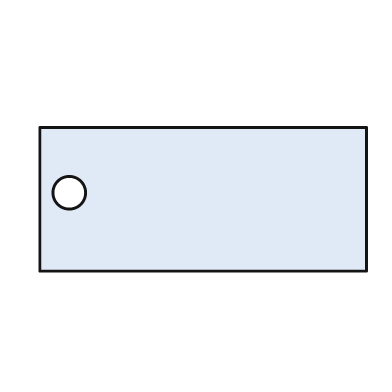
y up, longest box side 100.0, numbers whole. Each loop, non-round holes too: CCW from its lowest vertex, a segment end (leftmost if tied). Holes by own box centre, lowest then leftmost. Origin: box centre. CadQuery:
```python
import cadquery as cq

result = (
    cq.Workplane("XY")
    .moveTo(-50.0, -22.0)
    .lineTo(50.0, -22.0)
    .lineTo(50.0, 22.0)
    .lineTo(-50.0, 22.0)
    .close()
    .moveTo(-41.0, 2.0)
    .circle(5.0)
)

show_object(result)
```